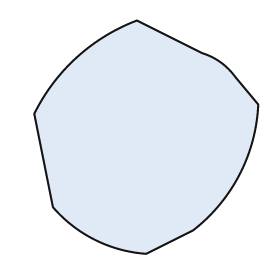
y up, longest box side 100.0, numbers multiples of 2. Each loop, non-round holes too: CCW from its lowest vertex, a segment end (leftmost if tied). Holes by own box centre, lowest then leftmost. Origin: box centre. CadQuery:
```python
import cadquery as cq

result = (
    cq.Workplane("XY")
    .moveTo(0.0, -50.0)
    .lineTo(20.0, -40.0)
    .threePointArc((40.0, -16.0), (48.0, 14.0))
    .lineTo(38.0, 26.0)
    .threePointArc((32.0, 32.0), (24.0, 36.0))
    .lineTo(-4.0, 50.0)
    .threePointArc((-30.0, 34.0), (-48.0, 10.0))
    .lineTo(-40.0, -30.0)
    .threePointArc((-22.0, -44.0), (0.0, -50.0))
    .close()
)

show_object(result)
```